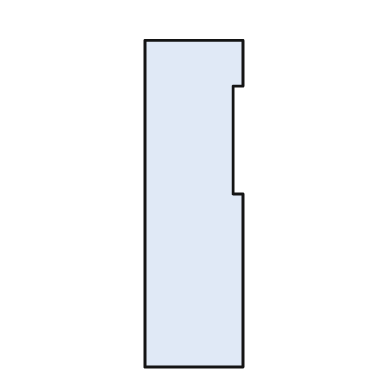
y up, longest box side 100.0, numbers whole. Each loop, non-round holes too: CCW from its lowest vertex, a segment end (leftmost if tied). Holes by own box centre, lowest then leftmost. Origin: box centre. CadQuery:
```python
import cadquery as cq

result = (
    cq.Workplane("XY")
    .moveTo(-15.0, -50.0)
    .lineTo(15.0, -50.0)
    .lineTo(15.0, 3.0)
    .lineTo(12.0, 3.0)
    .lineTo(12.0, 36.0)
    .lineTo(15.0, 36.0)
    .lineTo(15.0, 50.0)
    .lineTo(-15.0, 50.0)
    .close()
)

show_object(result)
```